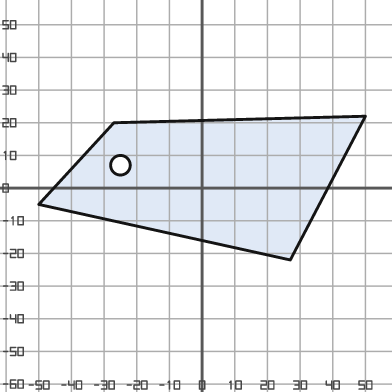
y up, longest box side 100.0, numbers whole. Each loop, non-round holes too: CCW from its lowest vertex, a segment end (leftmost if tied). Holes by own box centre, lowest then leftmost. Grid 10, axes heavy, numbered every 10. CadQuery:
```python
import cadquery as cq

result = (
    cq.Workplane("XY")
    .moveTo(27.0, -22.0)
    .lineTo(50.0, 22.0)
    .lineTo(-27.0, 20.0)
    .lineTo(-50.0, -5.0)
    .close()
    .moveTo(-25.0, 7.0)
    .circle(3.0)
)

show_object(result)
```